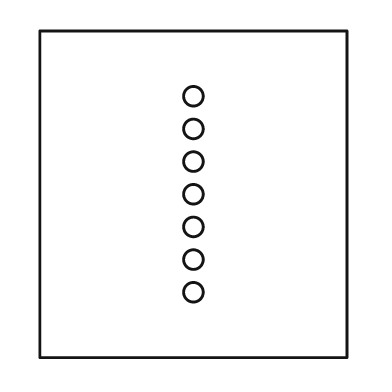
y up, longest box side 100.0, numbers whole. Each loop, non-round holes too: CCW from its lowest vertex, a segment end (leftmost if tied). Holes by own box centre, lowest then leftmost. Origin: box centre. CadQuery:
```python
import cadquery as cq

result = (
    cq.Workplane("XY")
    .moveTo(-47.0, -50.0)
    .lineTo(47.0, -50.0)
    .lineTo(47.0, 50.0)
    .lineTo(-47.0, 50.0)
    .close()
    .moveTo(0.0, -30.0)
    .circle(3.0)
    .moveTo(0.0, -20.0)
    .circle(3.0)
    .moveTo(0.0, -10.0)
    .circle(3.0)
    .moveTo(0.0, 0.0)
    .circle(3.0)
    .moveTo(0.0, 10.0)
    .circle(3.0)
    .moveTo(0.0, 20.0)
    .circle(3.0)
    .moveTo(0.0, 30.0)
    .circle(3.0)
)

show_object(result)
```